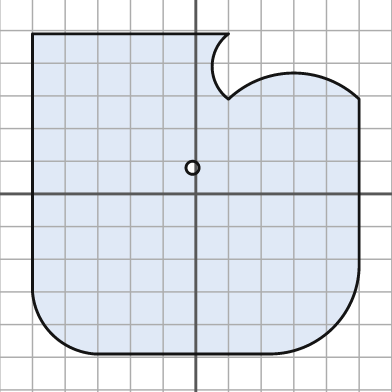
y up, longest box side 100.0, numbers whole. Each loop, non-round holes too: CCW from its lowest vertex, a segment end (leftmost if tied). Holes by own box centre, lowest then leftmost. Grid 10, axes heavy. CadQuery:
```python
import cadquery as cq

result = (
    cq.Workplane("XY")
    .moveTo(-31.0, -49.0)
    .lineTo(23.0, -49.0)
    .threePointArc((42.0, -41.0), (50.0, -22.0))
    .lineTo(50.0, 29.0)
    .threePointArc((30.0, 37.0), (10.0, 29.0))
    .threePointArc((5.0, 39.0), (10.0, 49.0))
    .lineTo(-50.0, 49.0)
    .lineTo(-50.0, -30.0)
    .threePointArc((-44.0, -43.0), (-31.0, -49.0))
    .close()
    .moveTo(-1.0, 8.0)
    .circle(2.0)
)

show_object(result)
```